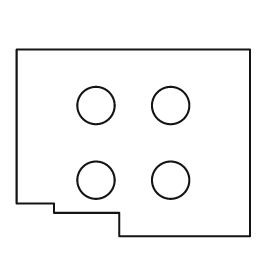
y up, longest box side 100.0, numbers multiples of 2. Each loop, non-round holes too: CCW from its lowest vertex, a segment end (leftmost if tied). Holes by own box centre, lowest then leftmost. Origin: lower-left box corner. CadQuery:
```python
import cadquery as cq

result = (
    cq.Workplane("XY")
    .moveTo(44.0, 0.0)
    .lineTo(100.0, 0.0)
    .lineTo(100.0, 80.0)
    .lineTo(0.0, 80.0)
    .lineTo(0.0, 14.0)
    .lineTo(16.0, 14.0)
    .lineTo(16.0, 10.0)
    .lineTo(44.0, 10.0)
    .close()
    .moveTo(34.0, 24.0)
    .circle(8.0)
    .moveTo(66.0, 24.0)
    .circle(8.0)
    .moveTo(34.0, 56.0)
    .circle(8.0)
    .moveTo(66.0, 56.0)
    .circle(8.0)
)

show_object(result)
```